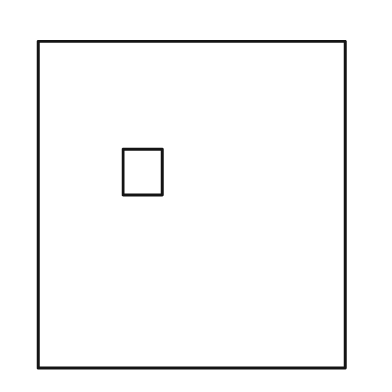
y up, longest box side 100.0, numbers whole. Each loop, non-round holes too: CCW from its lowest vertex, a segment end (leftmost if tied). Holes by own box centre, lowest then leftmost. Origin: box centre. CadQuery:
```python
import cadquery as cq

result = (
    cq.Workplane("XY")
    .moveTo(-47.0, -50.0)
    .lineTo(47.0, -50.0)
    .lineTo(47.0, 50.0)
    .lineTo(-47.0, 50.0)
    .close()
    .moveTo(-21.0, 3.0)
    .lineTo(-9.0, 3.0)
    .lineTo(-9.0, 17.0)
    .lineTo(-21.0, 17.0)
    .close()
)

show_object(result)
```